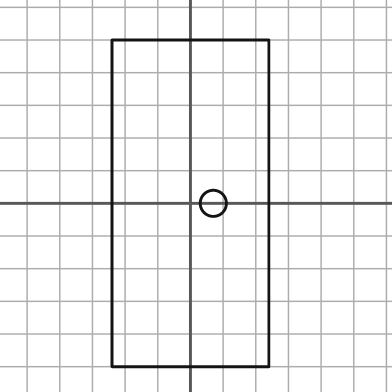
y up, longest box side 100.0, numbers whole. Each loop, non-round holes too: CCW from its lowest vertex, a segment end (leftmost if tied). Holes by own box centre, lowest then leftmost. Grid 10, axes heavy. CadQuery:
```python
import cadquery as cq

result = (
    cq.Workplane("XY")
    .moveTo(-24.0, -50.0)
    .lineTo(24.0, -50.0)
    .lineTo(24.0, 50.0)
    .lineTo(-24.0, 50.0)
    .close()
    .moveTo(7.0, 0.0)
    .circle(4.0)
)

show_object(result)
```